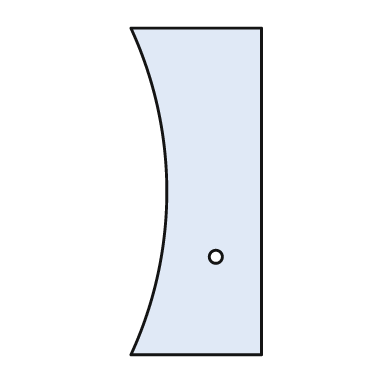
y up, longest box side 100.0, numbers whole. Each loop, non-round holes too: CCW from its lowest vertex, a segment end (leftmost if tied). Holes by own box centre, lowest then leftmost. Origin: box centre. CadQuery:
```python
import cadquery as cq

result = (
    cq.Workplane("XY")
    .moveTo(-20.0, -50.0)
    .lineTo(20.0, -50.0)
    .lineTo(20.0, 50.0)
    .lineTo(-20.0, 50.0)
    .threePointArc((-9.0, 0.0), (-20.0, -50.0))
    .close()
    .moveTo(6.0, -20.0)
    .circle(2.0)
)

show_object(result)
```